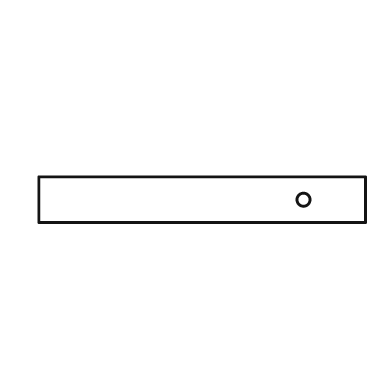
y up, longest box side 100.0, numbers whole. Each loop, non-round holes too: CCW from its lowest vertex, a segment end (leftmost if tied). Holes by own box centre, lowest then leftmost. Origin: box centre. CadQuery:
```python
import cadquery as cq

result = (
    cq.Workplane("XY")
    .moveTo(-50.0, -7.0)
    .lineTo(50.0, -7.0)
    .lineTo(50.0, 7.0)
    .lineTo(-50.0, 7.0)
    .close()
    .moveTo(31.0, 0.0)
    .circle(2.0)
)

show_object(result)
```